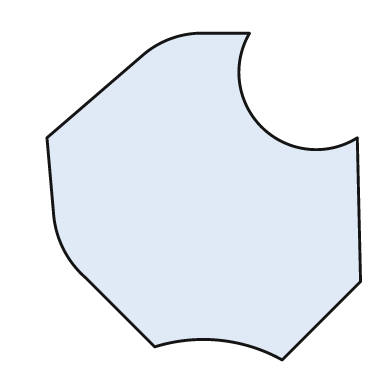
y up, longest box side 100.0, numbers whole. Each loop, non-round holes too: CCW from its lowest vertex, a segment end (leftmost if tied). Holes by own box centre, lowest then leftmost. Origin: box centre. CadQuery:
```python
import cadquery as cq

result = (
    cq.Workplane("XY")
    .moveTo(24.0, -50.0)
    .lineTo(48.0, -26.0)
    .lineTo(47.0, 18.0)
    .threePointArc((18.0, 21.0), (14.0, 50.0))
    .lineTo(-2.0, 50.0)
    .threePointArc((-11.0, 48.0), (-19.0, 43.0))
    .lineTo(-48.0, 18.0)
    .lineTo(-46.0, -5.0)
    .threePointArc((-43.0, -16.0), (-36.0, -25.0))
    .lineTo(-15.0, -46.0)
    .threePointArc((5.0, -44.0), (24.0, -50.0))
    .close()
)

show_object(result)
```